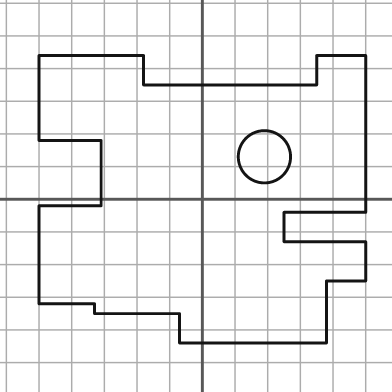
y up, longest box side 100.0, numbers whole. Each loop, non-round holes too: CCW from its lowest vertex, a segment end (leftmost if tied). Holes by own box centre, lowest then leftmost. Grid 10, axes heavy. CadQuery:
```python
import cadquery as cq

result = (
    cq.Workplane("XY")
    .moveTo(-7.0, -44.0)
    .lineTo(38.0, -44.0)
    .lineTo(38.0, -25.0)
    .lineTo(50.0, -25.0)
    .lineTo(50.0, -13.0)
    .lineTo(25.0, -13.0)
    .lineTo(25.0, -4.0)
    .lineTo(50.0, -4.0)
    .lineTo(50.0, 44.0)
    .lineTo(35.0, 44.0)
    .lineTo(35.0, 35.0)
    .lineTo(-18.0, 35.0)
    .lineTo(-18.0, 44.0)
    .lineTo(-50.0, 44.0)
    .lineTo(-50.0, 18.0)
    .lineTo(-31.0, 18.0)
    .lineTo(-31.0, -2.0)
    .lineTo(-50.0, -2.0)
    .lineTo(-50.0, -32.0)
    .lineTo(-33.0, -32.0)
    .lineTo(-33.0, -35.0)
    .lineTo(-7.0, -35.0)
    .close()
    .moveTo(19.0, 13.0)
    .circle(8.0)
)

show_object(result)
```